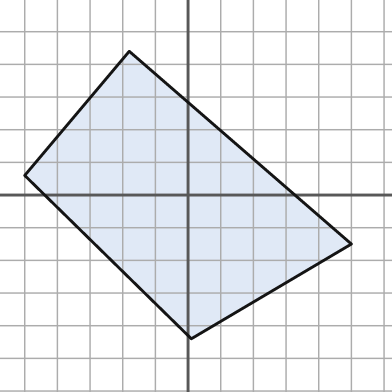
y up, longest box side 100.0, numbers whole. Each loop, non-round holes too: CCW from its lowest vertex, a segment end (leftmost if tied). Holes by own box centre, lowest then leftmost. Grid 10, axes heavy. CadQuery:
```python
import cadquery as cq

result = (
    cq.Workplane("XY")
    .moveTo(1.0, -44.0)
    .lineTo(50.0, -15.0)
    .lineTo(-18.0, 44.0)
    .lineTo(-50.0, 6.0)
    .close()
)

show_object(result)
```